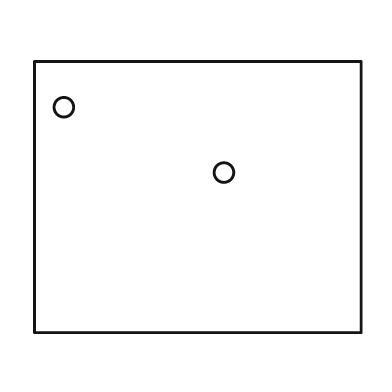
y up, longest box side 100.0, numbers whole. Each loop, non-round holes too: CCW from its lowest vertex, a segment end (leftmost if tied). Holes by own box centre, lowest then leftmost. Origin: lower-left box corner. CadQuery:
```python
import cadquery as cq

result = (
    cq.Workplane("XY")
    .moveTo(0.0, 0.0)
    .lineTo(100.0, 0.0)
    .lineTo(100.0, 83.0)
    .lineTo(0.0, 83.0)
    .close()
    .moveTo(58.0, 49.0)
    .circle(3.0)
    .moveTo(9.0, 69.0)
    .circle(3.0)
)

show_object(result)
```